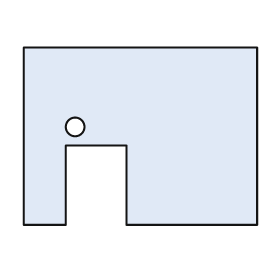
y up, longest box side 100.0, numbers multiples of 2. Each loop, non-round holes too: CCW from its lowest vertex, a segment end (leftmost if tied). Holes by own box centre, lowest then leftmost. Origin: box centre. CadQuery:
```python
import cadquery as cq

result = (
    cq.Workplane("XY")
    .moveTo(-50.0, -38.0)
    .lineTo(-32.0, -38.0)
    .lineTo(-32.0, -4.0)
    .lineTo(-6.0, -4.0)
    .lineTo(-6.0, -38.0)
    .lineTo(50.0, -38.0)
    .lineTo(50.0, 38.0)
    .lineTo(-50.0, 38.0)
    .close()
    .moveTo(-28.0, 4.0)
    .circle(4.0)
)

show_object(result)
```